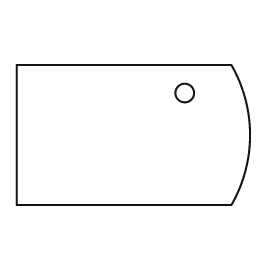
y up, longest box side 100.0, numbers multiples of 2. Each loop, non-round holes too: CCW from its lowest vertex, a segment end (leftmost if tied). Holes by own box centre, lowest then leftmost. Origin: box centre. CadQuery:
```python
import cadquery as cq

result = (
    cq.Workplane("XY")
    .moveTo(-50.0, -30.0)
    .lineTo(42.0, -30.0)
    .threePointArc((50.0, 0.0), (42.0, 30.0))
    .lineTo(-50.0, 30.0)
    .close()
    .moveTo(22.0, 18.0)
    .circle(4.0)
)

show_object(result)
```